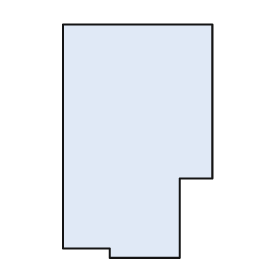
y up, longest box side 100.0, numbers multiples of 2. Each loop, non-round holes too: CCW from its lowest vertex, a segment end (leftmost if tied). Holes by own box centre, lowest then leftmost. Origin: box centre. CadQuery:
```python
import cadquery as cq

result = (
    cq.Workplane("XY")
    .moveTo(-12.0, -50.0)
    .lineTo(18.0, -50.0)
    .lineTo(18.0, -16.0)
    .lineTo(32.0, -16.0)
    .lineTo(32.0, 50.0)
    .lineTo(-32.0, 50.0)
    .lineTo(-32.0, -46.0)
    .lineTo(-12.0, -46.0)
    .close()
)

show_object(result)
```